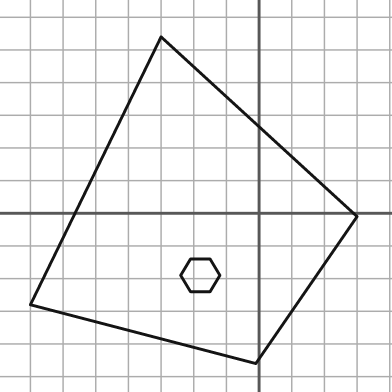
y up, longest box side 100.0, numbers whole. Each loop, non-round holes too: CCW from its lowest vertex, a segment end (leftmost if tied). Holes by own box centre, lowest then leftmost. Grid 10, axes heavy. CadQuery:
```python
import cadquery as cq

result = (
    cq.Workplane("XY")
    .moveTo(-1.0, -46.0)
    .lineTo(30.0, -1.0)
    .lineTo(-30.0, 54.0)
    .lineTo(-70.0, -28.0)
    .close()
    .moveTo(-21.0, -24.0)
    .lineTo(-15.0, -24.0)
    .lineTo(-12.0, -19.0)
    .lineTo(-15.0, -14.0)
    .lineTo(-21.0, -14.0)
    .lineTo(-24.0, -19.0)
    .close()
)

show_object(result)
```